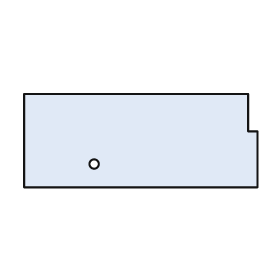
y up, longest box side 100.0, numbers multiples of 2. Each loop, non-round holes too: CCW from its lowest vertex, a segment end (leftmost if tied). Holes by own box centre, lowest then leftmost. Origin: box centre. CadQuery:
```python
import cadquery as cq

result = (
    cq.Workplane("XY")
    .moveTo(-50.0, -20.0)
    .lineTo(50.0, -20.0)
    .lineTo(50.0, 4.0)
    .lineTo(46.0, 4.0)
    .lineTo(46.0, 20.0)
    .lineTo(-50.0, 20.0)
    .close()
    .moveTo(-20.0, -10.0)
    .circle(2.0)
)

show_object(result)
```